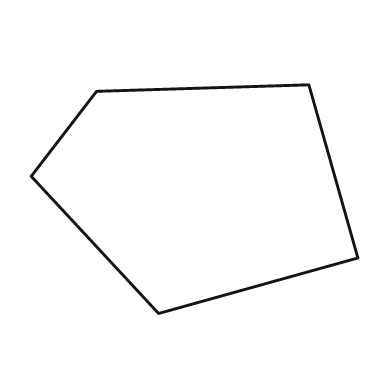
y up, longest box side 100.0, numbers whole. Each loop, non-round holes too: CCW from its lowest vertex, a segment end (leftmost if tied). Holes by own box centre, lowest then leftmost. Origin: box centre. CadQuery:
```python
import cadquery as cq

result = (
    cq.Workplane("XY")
    .moveTo(-11.0, -35.0)
    .lineTo(50.0, -18.0)
    .lineTo(35.0, 35.0)
    .lineTo(-30.0, 33.0)
    .lineTo(-50.0, 7.0)
    .close()
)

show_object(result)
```